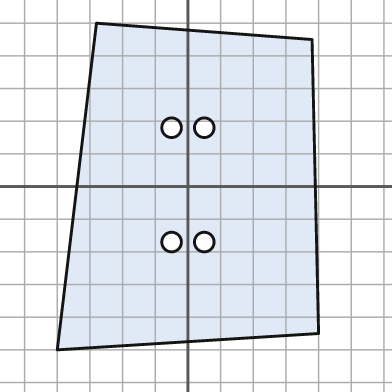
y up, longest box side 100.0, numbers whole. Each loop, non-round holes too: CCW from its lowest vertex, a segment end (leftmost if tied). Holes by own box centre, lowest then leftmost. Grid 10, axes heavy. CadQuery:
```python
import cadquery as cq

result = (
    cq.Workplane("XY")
    .moveTo(-40.0, -50.0)
    .lineTo(40.0, -45.0)
    .lineTo(38.0, 45.0)
    .lineTo(-28.0, 50.0)
    .close()
    .moveTo(-5.0, -17.0)
    .circle(3.0)
    .moveTo(5.0, -17.0)
    .circle(3.0)
    .moveTo(-5.0, 18.0)
    .circle(3.0)
    .moveTo(5.0, 18.0)
    .circle(3.0)
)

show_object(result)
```